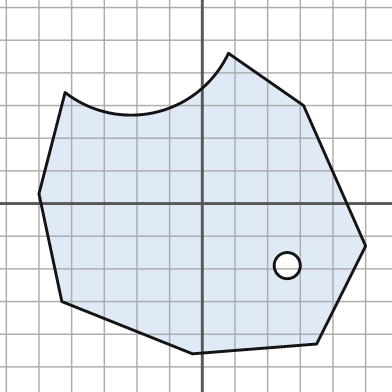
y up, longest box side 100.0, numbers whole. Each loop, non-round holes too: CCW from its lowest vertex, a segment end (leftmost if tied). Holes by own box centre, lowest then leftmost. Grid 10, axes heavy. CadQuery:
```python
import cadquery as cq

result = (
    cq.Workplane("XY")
    .moveTo(-3.0, -46.0)
    .lineTo(35.0, -43.0)
    .lineTo(50.0, -13.0)
    .lineTo(31.0, 30.0)
    .lineTo(8.0, 46.0)
    .threePointArc((-14.0, 28.0), (-42.0, 34.0))
    .lineTo(-50.0, 3.0)
    .lineTo(-43.0, -30.0)
    .close()
    .moveTo(26.0, -19.0)
    .circle(4.0)
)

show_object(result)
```